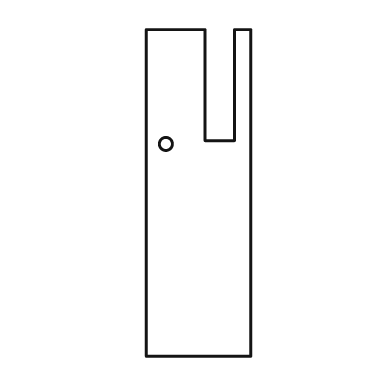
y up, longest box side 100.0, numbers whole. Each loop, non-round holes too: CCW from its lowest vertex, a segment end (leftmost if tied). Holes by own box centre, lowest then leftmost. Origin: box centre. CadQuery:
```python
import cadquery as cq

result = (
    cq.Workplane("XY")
    .moveTo(-16.0, -50.0)
    .lineTo(16.0, -50.0)
    .lineTo(16.0, 50.0)
    .lineTo(11.0, 50.0)
    .lineTo(11.0, 16.0)
    .lineTo(2.0, 16.0)
    .lineTo(2.0, 50.0)
    .lineTo(-16.0, 50.0)
    .close()
    .moveTo(-10.0, 15.0)
    .circle(2.0)
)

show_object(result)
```